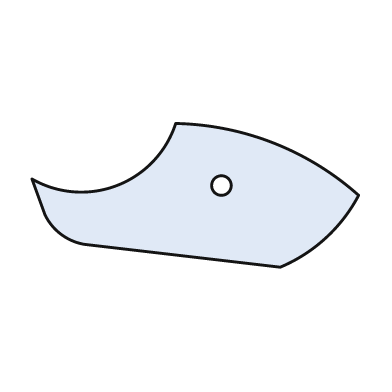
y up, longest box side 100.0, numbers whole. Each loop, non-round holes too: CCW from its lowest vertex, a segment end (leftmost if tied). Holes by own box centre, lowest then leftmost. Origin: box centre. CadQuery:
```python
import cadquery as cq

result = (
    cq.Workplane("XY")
    .moveTo(26.0, -22.0)
    .threePointArc((40.0, -13.0), (50.0, 0.0))
    .threePointArc((24.0, 16.0), (-6.0, 22.0))
    .threePointArc((-24.0, 3.0), (-50.0, 5.0))
    .lineTo(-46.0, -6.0)
    .threePointArc((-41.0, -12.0), (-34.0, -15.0))
    .close()
    .moveTo(8.0, 3.0)
    .circle(3.0)
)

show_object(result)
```